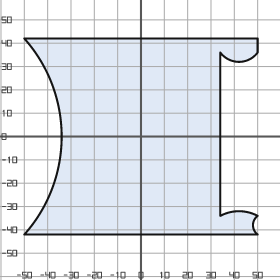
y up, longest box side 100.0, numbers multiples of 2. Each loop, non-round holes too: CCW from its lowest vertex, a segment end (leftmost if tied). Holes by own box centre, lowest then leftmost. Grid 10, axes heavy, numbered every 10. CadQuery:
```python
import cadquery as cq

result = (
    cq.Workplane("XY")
    .moveTo(-50.0, -42.0)
    .lineTo(50.0, -42.0)
    .threePointArc((48.0, -38.0), (50.0, -34.0))
    .threePointArc((42.0, -32.0), (34.0, -34.0))
    .lineTo(34.0, 36.0)
    .threePointArc((42.0, 32.0), (50.0, 36.0))
    .lineTo(50.0, 42.0)
    .lineTo(-50.0, 42.0)
    .threePointArc((-34.0, 0.0), (-50.0, -42.0))
    .close()
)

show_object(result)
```